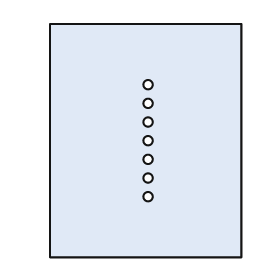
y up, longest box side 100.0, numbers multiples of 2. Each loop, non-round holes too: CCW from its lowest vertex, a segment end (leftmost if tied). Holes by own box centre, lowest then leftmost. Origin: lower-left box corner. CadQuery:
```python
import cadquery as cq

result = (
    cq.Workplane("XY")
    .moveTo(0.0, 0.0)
    .lineTo(82.0, 0.0)
    .lineTo(82.0, 100.0)
    .lineTo(0.0, 100.0)
    .close()
    .moveTo(42.0, 26.0)
    .circle(2.0)
    .moveTo(42.0, 34.0)
    .circle(2.0)
    .moveTo(42.0, 42.0)
    .circle(2.0)
    .moveTo(42.0, 50.0)
    .circle(2.0)
    .moveTo(42.0, 58.0)
    .circle(2.0)
    .moveTo(42.0, 66.0)
    .circle(2.0)
    .moveTo(42.0, 74.0)
    .circle(2.0)
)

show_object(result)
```